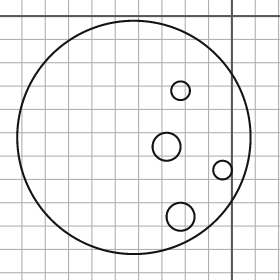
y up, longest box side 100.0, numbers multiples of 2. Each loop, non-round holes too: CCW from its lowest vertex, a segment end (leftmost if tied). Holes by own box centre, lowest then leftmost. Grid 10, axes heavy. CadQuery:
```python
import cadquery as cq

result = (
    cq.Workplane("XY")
    .moveTo(-42.0, -52.0)
    .circle(50.0)
    .moveTo(-22.0, -86.0)
    .circle(6.0)
    .moveTo(-4.0, -66.0)
    .circle(4.0)
    .moveTo(-28.0, -56.0)
    .circle(6.0)
    .moveTo(-22.0, -32.0)
    .circle(4.0)
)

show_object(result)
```